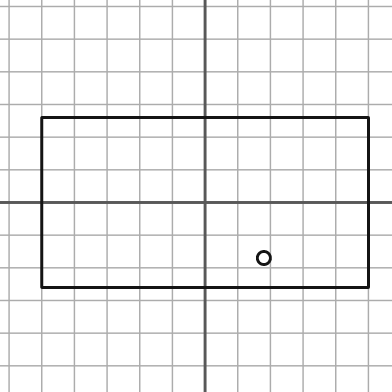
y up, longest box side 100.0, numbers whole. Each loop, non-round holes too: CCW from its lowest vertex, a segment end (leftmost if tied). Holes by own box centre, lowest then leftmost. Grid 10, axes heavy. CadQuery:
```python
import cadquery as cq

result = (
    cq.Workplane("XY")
    .moveTo(-50.0, -26.0)
    .lineTo(50.0, -26.0)
    .lineTo(50.0, 26.0)
    .lineTo(-50.0, 26.0)
    .close()
    .moveTo(18.0, -17.0)
    .circle(2.0)
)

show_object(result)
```